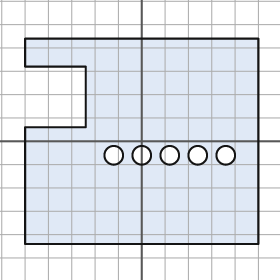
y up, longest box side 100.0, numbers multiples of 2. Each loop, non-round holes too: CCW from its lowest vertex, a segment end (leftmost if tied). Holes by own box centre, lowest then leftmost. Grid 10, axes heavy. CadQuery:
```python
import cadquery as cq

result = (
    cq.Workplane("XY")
    .moveTo(-50.0, -44.0)
    .lineTo(50.0, -44.0)
    .lineTo(50.0, 44.0)
    .lineTo(-50.0, 44.0)
    .lineTo(-50.0, 32.0)
    .lineTo(-24.0, 32.0)
    .lineTo(-24.0, 6.0)
    .lineTo(-50.0, 6.0)
    .close()
    .moveTo(-12.0, -6.0)
    .circle(4.0)
    .moveTo(0.0, -6.0)
    .circle(4.0)
    .moveTo(12.0, -6.0)
    .circle(4.0)
    .moveTo(24.0, -6.0)
    .circle(4.0)
    .moveTo(36.0, -6.0)
    .circle(4.0)
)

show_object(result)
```